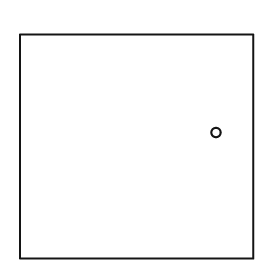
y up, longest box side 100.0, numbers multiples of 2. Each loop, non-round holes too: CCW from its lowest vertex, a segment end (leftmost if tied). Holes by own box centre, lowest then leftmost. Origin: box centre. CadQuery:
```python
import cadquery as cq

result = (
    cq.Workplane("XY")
    .moveTo(-50.0, -48.0)
    .lineTo(50.0, -48.0)
    .lineTo(50.0, 48.0)
    .lineTo(-50.0, 48.0)
    .close()
    .moveTo(34.0, 6.0)
    .circle(2.0)
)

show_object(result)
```